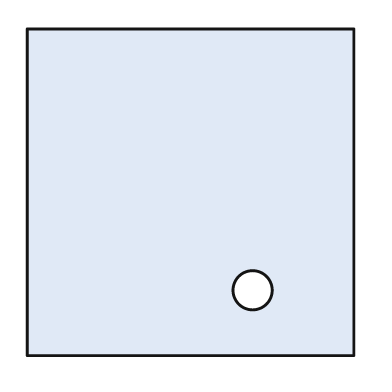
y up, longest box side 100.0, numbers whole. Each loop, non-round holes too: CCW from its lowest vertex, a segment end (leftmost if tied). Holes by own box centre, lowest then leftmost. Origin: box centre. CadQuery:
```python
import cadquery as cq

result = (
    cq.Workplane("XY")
    .moveTo(-50.0, -50.0)
    .lineTo(50.0, -50.0)
    .lineTo(50.0, 50.0)
    .lineTo(-50.0, 50.0)
    .close()
    .moveTo(19.0, -30.0)
    .circle(6.0)
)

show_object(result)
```